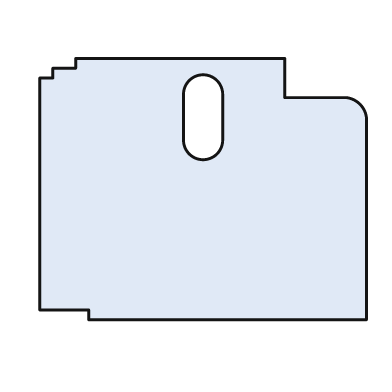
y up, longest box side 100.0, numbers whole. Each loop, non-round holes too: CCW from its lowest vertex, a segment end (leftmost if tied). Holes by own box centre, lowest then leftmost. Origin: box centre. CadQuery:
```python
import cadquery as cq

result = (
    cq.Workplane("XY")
    .moveTo(-35.0, -40.0)
    .lineTo(50.0, -40.0)
    .lineTo(50.0, 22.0)
    .threePointArc((48.0, 26.0), (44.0, 28.0))
    .lineTo(25.0, 28.0)
    .lineTo(25.0, 40.0)
    .lineTo(-39.0, 40.0)
    .lineTo(-39.0, 37.0)
    .lineTo(-46.0, 37.0)
    .lineTo(-46.0, 34.0)
    .lineTo(-50.0, 34.0)
    .lineTo(-50.0, -37.0)
    .lineTo(-35.0, -37.0)
    .close()
    .moveTo(-6.0, 15.0)
    .threePointArc((0.0, 9.0), (6.0, 15.0))
    .lineTo(6.0, 29.0)
    .threePointArc((0.0, 35.0), (-6.0, 29.0))
    .close()
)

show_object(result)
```